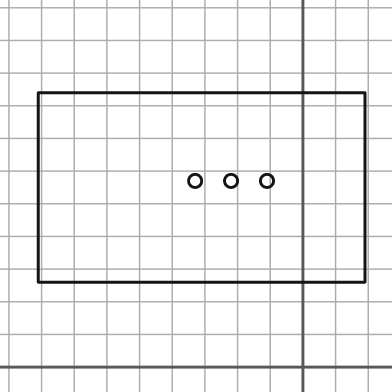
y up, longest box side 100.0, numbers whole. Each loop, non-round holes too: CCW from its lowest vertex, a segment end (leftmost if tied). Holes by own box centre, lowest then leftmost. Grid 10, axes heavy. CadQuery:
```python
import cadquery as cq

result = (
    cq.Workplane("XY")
    .moveTo(-81.0, 26.0)
    .lineTo(19.0, 26.0)
    .lineTo(19.0, 84.0)
    .lineTo(-81.0, 84.0)
    .close()
    .moveTo(-33.0, 57.0)
    .circle(2.0)
    .moveTo(-22.0, 57.0)
    .circle(2.0)
    .moveTo(-11.0, 57.0)
    .circle(2.0)
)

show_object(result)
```